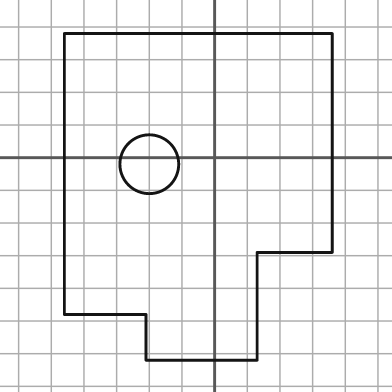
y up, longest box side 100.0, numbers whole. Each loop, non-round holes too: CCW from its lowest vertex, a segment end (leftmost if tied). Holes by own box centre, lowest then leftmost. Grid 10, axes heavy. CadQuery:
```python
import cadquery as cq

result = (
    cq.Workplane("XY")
    .moveTo(-21.0, -62.0)
    .lineTo(13.0, -62.0)
    .lineTo(13.0, -29.0)
    .lineTo(36.0, -29.0)
    .lineTo(36.0, 38.0)
    .lineTo(-46.0, 38.0)
    .lineTo(-46.0, -48.0)
    .lineTo(-21.0, -48.0)
    .close()
    .moveTo(-20.0, -2.0)
    .circle(9.0)
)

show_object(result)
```